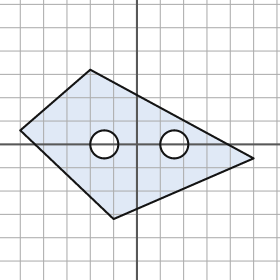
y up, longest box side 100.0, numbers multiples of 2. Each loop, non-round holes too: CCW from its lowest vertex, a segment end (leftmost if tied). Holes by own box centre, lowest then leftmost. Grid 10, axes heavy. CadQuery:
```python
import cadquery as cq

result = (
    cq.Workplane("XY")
    .moveTo(-10.0, -32.0)
    .lineTo(50.0, -6.0)
    .lineTo(-20.0, 32.0)
    .lineTo(-50.0, 6.0)
    .close()
    .moveTo(-14.0, 0.0)
    .circle(6.0)
    .moveTo(16.0, 0.0)
    .circle(6.0)
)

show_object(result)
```